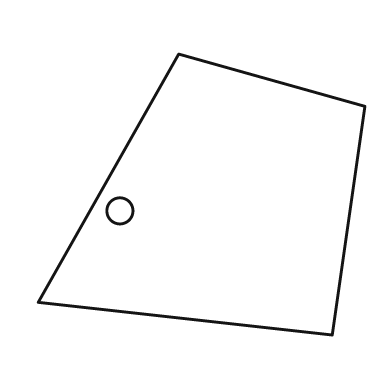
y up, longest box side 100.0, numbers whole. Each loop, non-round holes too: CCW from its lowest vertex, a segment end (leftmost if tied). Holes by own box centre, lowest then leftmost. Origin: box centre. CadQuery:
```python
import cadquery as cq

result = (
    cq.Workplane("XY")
    .moveTo(40.0, -43.0)
    .lineTo(50.0, 27.0)
    .lineTo(-7.0, 43.0)
    .lineTo(-50.0, -33.0)
    .close()
    .moveTo(-25.0, -5.0)
    .circle(4.0)
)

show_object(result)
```